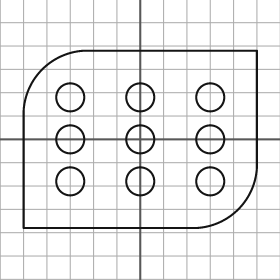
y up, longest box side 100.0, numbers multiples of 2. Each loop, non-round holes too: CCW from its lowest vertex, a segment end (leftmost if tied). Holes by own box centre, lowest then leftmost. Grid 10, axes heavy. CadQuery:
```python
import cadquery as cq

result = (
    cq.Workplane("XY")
    .moveTo(-50.0, -38.0)
    .lineTo(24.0, -38.0)
    .threePointArc((42.0, -30.0), (50.0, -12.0))
    .lineTo(50.0, 38.0)
    .lineTo(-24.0, 38.0)
    .threePointArc((-42.0, 30.0), (-50.0, 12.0))
    .close()
    .moveTo(-30.0, -18.0)
    .circle(6.0)
    .moveTo(0.0, -18.0)
    .circle(6.0)
    .moveTo(30.0, -18.0)
    .circle(6.0)
    .moveTo(-30.0, 0.0)
    .circle(6.0)
    .moveTo(0.0, 0.0)
    .circle(6.0)
    .moveTo(30.0, 0.0)
    .circle(6.0)
    .moveTo(-30.0, 18.0)
    .circle(6.0)
    .moveTo(0.0, 18.0)
    .circle(6.0)
    .moveTo(30.0, 18.0)
    .circle(6.0)
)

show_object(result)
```